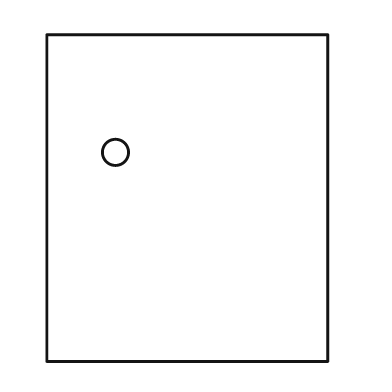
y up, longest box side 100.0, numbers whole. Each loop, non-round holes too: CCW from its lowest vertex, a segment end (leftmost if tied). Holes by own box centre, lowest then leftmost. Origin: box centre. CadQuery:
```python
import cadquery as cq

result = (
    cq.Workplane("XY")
    .moveTo(-43.0, -50.0)
    .lineTo(43.0, -50.0)
    .lineTo(43.0, 50.0)
    .lineTo(-43.0, 50.0)
    .close()
    .moveTo(-22.0, 14.0)
    .circle(4.0)
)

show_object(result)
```